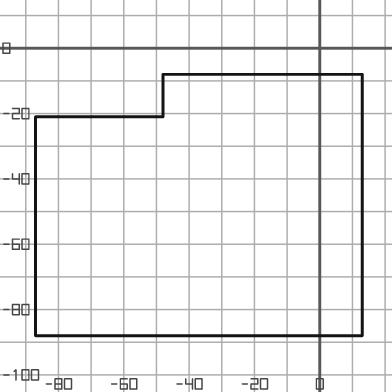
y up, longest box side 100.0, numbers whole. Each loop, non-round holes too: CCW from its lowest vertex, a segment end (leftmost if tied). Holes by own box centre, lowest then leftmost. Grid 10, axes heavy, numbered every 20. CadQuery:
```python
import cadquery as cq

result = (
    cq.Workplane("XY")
    .moveTo(-87.0, -88.0)
    .lineTo(13.0, -88.0)
    .lineTo(13.0, -8.0)
    .lineTo(-48.0, -8.0)
    .lineTo(-48.0, -21.0)
    .lineTo(-87.0, -21.0)
    .close()
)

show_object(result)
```